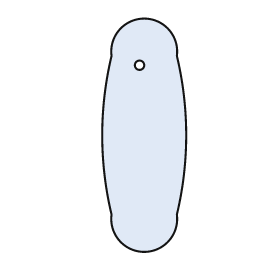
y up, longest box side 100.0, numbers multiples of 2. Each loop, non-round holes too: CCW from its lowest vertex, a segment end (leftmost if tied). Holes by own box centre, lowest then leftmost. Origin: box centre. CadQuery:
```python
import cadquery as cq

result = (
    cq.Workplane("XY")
    .moveTo(-14.0, -34.0)
    .threePointArc((0.0, -50.0), (14.0, -34.0))
    .threePointArc((18.0, 0.0), (14.0, 34.0))
    .threePointArc((0.0, 50.0), (-14.0, 34.0))
    .threePointArc((-18.0, 0.0), (-14.0, -34.0))
    .close()
    .moveTo(-2.0, 30.0)
    .circle(2.0)
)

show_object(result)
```